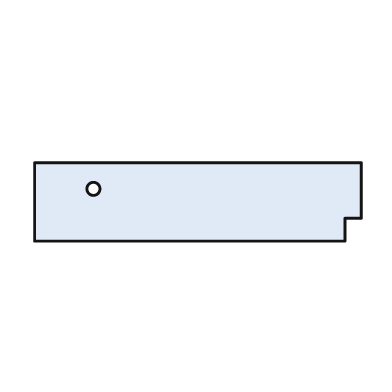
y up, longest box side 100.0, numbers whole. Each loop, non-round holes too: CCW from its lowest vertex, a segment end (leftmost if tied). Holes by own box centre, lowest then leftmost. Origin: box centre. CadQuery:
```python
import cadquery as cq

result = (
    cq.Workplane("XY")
    .moveTo(-50.0, -12.0)
    .lineTo(45.0, -12.0)
    .lineTo(45.0, -5.0)
    .lineTo(50.0, -5.0)
    .lineTo(50.0, 12.0)
    .lineTo(-50.0, 12.0)
    .close()
    .moveTo(-32.0, 4.0)
    .circle(2.0)
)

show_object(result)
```